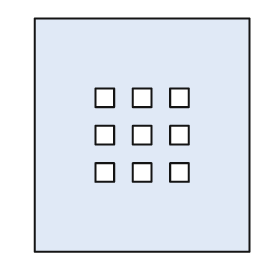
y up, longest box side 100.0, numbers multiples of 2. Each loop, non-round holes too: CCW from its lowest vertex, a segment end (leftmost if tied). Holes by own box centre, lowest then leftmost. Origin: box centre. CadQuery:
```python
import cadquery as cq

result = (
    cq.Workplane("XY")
    .moveTo(-46.0, -50.0)
    .lineTo(46.0, -50.0)
    .lineTo(46.0, 50.0)
    .lineTo(-46.0, 50.0)
    .close()
    .moveTo(-20.0, -20.0)
    .lineTo(-12.0, -20.0)
    .lineTo(-12.0, -12.0)
    .lineTo(-20.0, -12.0)
    .close()
    .moveTo(-4.0, -20.0)
    .lineTo(4.0, -20.0)
    .lineTo(4.0, -12.0)
    .lineTo(-4.0, -12.0)
    .close()
    .moveTo(12.0, -20.0)
    .lineTo(20.0, -20.0)
    .lineTo(20.0, -12.0)
    .lineTo(12.0, -12.0)
    .close()
    .moveTo(-20.0, -4.0)
    .lineTo(-12.0, -4.0)
    .lineTo(-12.0, 4.0)
    .lineTo(-20.0, 4.0)
    .close()
    .moveTo(-4.0, -4.0)
    .lineTo(4.0, -4.0)
    .lineTo(4.0, 4.0)
    .lineTo(-4.0, 4.0)
    .close()
    .moveTo(12.0, -4.0)
    .lineTo(20.0, -4.0)
    .lineTo(20.0, 4.0)
    .lineTo(12.0, 4.0)
    .close()
    .moveTo(-20.0, 12.0)
    .lineTo(-12.0, 12.0)
    .lineTo(-12.0, 20.0)
    .lineTo(-20.0, 20.0)
    .close()
    .moveTo(-4.0, 12.0)
    .lineTo(4.0, 12.0)
    .lineTo(4.0, 20.0)
    .lineTo(-4.0, 20.0)
    .close()
    .moveTo(12.0, 12.0)
    .lineTo(20.0, 12.0)
    .lineTo(20.0, 20.0)
    .lineTo(12.0, 20.0)
    .close()
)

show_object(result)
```